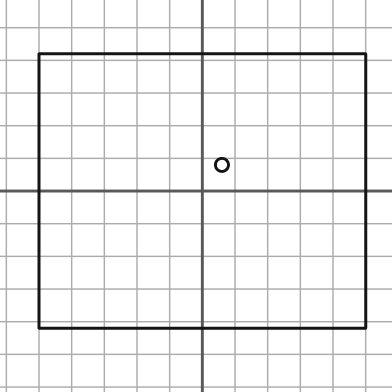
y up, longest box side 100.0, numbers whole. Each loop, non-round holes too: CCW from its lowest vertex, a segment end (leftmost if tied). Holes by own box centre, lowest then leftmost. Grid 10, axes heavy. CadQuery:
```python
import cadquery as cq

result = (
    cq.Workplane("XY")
    .moveTo(-50.0, -42.0)
    .lineTo(50.0, -42.0)
    .lineTo(50.0, 42.0)
    .lineTo(-50.0, 42.0)
    .close()
    .moveTo(6.0, 8.0)
    .circle(2.0)
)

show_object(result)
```